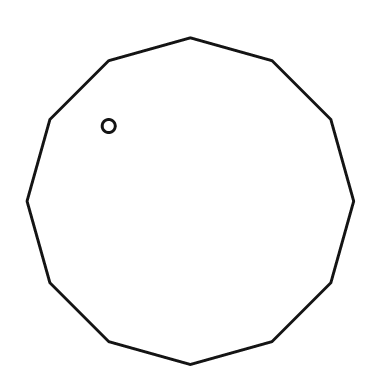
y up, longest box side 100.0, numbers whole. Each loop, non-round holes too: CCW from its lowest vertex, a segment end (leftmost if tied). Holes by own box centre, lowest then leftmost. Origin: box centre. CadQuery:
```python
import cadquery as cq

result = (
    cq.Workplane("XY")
    .moveTo(0.0, -50.0)
    .lineTo(25.0, -43.0)
    .lineTo(43.0, -25.0)
    .lineTo(50.0, 0.0)
    .lineTo(43.0, 25.0)
    .lineTo(25.0, 43.0)
    .lineTo(0.0, 50.0)
    .lineTo(-25.0, 43.0)
    .lineTo(-43.0, 25.0)
    .lineTo(-50.0, 0.0)
    .lineTo(-43.0, -25.0)
    .lineTo(-25.0, -43.0)
    .close()
    .moveTo(-25.0, 23.0)
    .circle(2.0)
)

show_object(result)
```